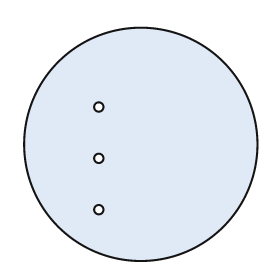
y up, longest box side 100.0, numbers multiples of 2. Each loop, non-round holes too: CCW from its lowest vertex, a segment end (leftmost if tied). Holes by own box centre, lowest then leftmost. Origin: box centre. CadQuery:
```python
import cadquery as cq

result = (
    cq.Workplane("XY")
    .moveTo(0.0, 0.0)
    .circle(50.0)
    .moveTo(-18.0, -28.0)
    .circle(2.0)
    .moveTo(-18.0, -6.0)
    .circle(2.0)
    .moveTo(-18.0, 16.0)
    .circle(2.0)
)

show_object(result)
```